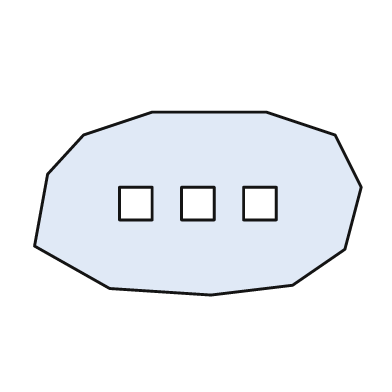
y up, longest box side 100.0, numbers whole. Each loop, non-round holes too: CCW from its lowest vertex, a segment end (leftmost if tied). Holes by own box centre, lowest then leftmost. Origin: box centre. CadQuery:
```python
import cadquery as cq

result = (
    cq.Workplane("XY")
    .moveTo(4.0, -28.0)
    .lineTo(29.0, -25.0)
    .lineTo(45.0, -14.0)
    .lineTo(50.0, 5.0)
    .lineTo(42.0, 21.0)
    .lineTo(21.0, 28.0)
    .lineTo(-14.0, 28.0)
    .lineTo(-35.0, 21.0)
    .lineTo(-46.0, 9.0)
    .lineTo(-50.0, -13.0)
    .lineTo(-27.0, -26.0)
    .close()
    .moveTo(-24.0, -5.0)
    .lineTo(-14.0, -5.0)
    .lineTo(-14.0, 5.0)
    .lineTo(-24.0, 5.0)
    .close()
    .moveTo(-5.0, -5.0)
    .lineTo(5.0, -5.0)
    .lineTo(5.0, 5.0)
    .lineTo(-5.0, 5.0)
    .close()
    .moveTo(14.0, -5.0)
    .lineTo(24.0, -5.0)
    .lineTo(24.0, 5.0)
    .lineTo(14.0, 5.0)
    .close()
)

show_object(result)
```